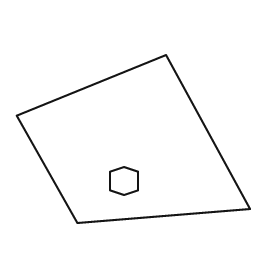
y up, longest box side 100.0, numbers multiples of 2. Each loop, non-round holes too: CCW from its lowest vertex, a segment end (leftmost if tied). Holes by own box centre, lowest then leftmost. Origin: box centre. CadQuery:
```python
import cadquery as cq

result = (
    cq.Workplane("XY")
    .moveTo(-24.0, -36.0)
    .lineTo(50.0, -30.0)
    .lineTo(14.0, 36.0)
    .lineTo(-50.0, 10.0)
    .close()
    .moveTo(-4.0, -24.0)
    .lineTo(2.0, -22.0)
    .lineTo(2.0, -14.0)
    .lineTo(-4.0, -12.0)
    .lineTo(-10.0, -14.0)
    .lineTo(-10.0, -22.0)
    .close()
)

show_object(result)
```